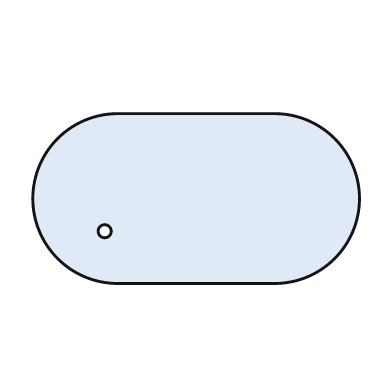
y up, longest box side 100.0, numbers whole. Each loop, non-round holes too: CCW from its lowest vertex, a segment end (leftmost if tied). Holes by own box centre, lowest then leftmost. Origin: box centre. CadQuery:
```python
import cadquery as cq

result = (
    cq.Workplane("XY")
    .moveTo(-24.0, -26.0)
    .lineTo(24.0, -26.0)
    .threePointArc((50.0, 0.0), (24.0, 26.0))
    .lineTo(-24.0, 26.0)
    .threePointArc((-50.0, 0.0), (-24.0, -26.0))
    .close()
    .moveTo(-28.0, -10.0)
    .circle(2.0)
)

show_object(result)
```